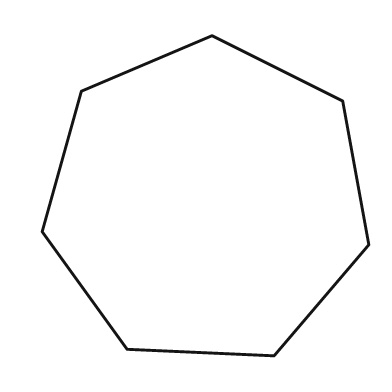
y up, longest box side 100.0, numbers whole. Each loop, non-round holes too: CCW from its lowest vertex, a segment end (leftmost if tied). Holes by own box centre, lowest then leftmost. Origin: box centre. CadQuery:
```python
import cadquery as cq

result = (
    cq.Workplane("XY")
    .moveTo(21.0, -49.0)
    .lineTo(50.0, -15.0)
    .lineTo(42.0, 29.0)
    .lineTo(2.0, 49.0)
    .lineTo(-38.0, 32.0)
    .lineTo(-50.0, -11.0)
    .lineTo(-24.0, -47.0)
    .close()
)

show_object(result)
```